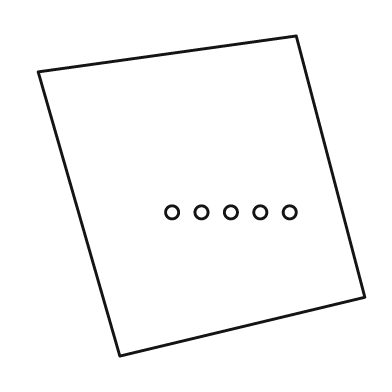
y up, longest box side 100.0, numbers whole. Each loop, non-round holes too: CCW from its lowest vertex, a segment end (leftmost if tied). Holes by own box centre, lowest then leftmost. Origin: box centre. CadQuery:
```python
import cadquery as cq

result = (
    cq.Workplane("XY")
    .moveTo(-25.0, -49.0)
    .lineTo(50.0, -31.0)
    .lineTo(29.0, 49.0)
    .lineTo(-50.0, 38.0)
    .close()
    .moveTo(-9.0, -5.0)
    .circle(2.0)
    .moveTo(0.0, -5.0)
    .circle(2.0)
    .moveTo(9.0, -5.0)
    .circle(2.0)
    .moveTo(18.0, -5.0)
    .circle(2.0)
    .moveTo(27.0, -5.0)
    .circle(2.0)
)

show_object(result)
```